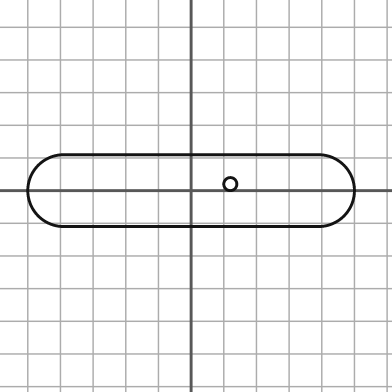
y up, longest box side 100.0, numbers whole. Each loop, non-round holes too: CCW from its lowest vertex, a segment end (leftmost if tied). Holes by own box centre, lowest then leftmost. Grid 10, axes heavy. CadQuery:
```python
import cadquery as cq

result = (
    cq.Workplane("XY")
    .moveTo(-39.0, -11.0)
    .lineTo(39.0, -11.0)
    .threePointArc((50.0, 0.0), (39.0, 11.0))
    .lineTo(-39.0, 11.0)
    .threePointArc((-50.0, 0.0), (-39.0, -11.0))
    .close()
    .moveTo(12.0, 2.0)
    .circle(2.0)
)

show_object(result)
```